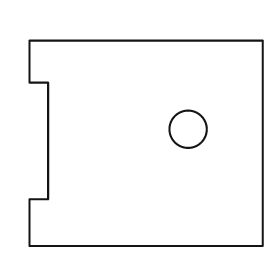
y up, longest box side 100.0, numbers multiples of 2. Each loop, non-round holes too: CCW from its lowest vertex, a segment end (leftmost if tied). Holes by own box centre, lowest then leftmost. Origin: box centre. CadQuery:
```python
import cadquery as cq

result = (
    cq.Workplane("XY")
    .moveTo(-50.0, -44.0)
    .lineTo(50.0, -44.0)
    .lineTo(50.0, 44.0)
    .lineTo(-50.0, 44.0)
    .lineTo(-50.0, 26.0)
    .lineTo(-42.0, 26.0)
    .lineTo(-42.0, -24.0)
    .lineTo(-50.0, -24.0)
    .close()
    .moveTo(18.0, 6.0)
    .circle(8.0)
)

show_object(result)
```